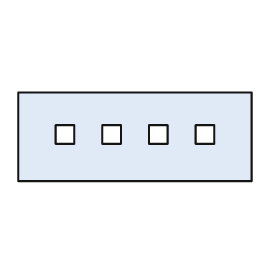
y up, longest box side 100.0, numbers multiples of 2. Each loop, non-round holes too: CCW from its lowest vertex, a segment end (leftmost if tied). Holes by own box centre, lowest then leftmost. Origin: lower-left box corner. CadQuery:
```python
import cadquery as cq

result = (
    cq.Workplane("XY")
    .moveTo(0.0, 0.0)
    .lineTo(100.0, 0.0)
    .lineTo(100.0, 38.0)
    .lineTo(0.0, 38.0)
    .close()
    .moveTo(16.0, 16.0)
    .lineTo(24.0, 16.0)
    .lineTo(24.0, 24.0)
    .lineTo(16.0, 24.0)
    .close()
    .moveTo(36.0, 16.0)
    .lineTo(44.0, 16.0)
    .lineTo(44.0, 24.0)
    .lineTo(36.0, 24.0)
    .close()
    .moveTo(56.0, 16.0)
    .lineTo(64.0, 16.0)
    .lineTo(64.0, 24.0)
    .lineTo(56.0, 24.0)
    .close()
    .moveTo(76.0, 16.0)
    .lineTo(84.0, 16.0)
    .lineTo(84.0, 24.0)
    .lineTo(76.0, 24.0)
    .close()
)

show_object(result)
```